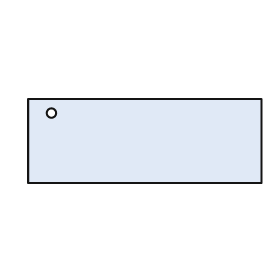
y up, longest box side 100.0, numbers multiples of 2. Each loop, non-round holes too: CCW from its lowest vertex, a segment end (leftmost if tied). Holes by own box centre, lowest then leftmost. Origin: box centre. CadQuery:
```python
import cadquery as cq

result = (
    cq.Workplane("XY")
    .moveTo(-50.0, -18.0)
    .lineTo(50.0, -18.0)
    .lineTo(50.0, 18.0)
    .lineTo(-50.0, 18.0)
    .close()
    .moveTo(-40.0, 12.0)
    .circle(2.0)
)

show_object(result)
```